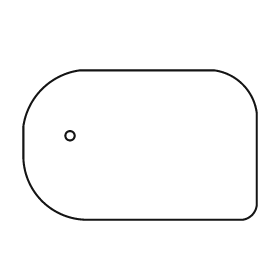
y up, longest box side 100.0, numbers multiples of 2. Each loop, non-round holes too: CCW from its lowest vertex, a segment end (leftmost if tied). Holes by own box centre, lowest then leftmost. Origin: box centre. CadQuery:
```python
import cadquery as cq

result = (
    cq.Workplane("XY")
    .moveTo(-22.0, -32.0)
    .lineTo(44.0, -32.0)
    .threePointArc((48.0, -30.0), (50.0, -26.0))
    .lineTo(50.0, 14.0)
    .threePointArc((44.0, 26.0), (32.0, 32.0))
    .lineTo(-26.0, 32.0)
    .threePointArc((-42.0, 24.0), (-50.0, 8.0))
    .lineTo(-50.0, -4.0)
    .threePointArc((-42.0, -24.0), (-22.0, -32.0))
    .close()
    .moveTo(-30.0, 4.0)
    .circle(2.0)
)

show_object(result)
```